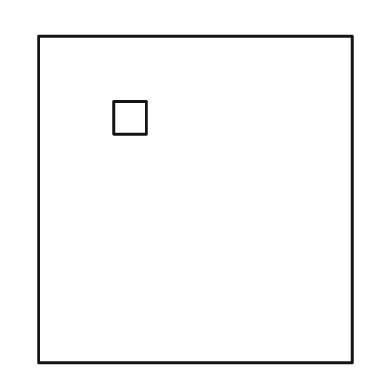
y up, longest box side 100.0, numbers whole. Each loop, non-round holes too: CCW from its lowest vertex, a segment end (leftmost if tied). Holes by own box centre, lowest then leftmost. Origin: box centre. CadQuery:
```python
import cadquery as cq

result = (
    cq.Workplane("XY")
    .moveTo(-48.0, -50.0)
    .lineTo(48.0, -50.0)
    .lineTo(48.0, 50.0)
    .lineTo(-48.0, 50.0)
    .close()
    .moveTo(-25.0, 20.0)
    .lineTo(-15.0, 20.0)
    .lineTo(-15.0, 30.0)
    .lineTo(-25.0, 30.0)
    .close()
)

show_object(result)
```